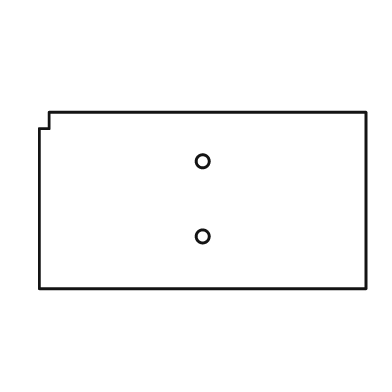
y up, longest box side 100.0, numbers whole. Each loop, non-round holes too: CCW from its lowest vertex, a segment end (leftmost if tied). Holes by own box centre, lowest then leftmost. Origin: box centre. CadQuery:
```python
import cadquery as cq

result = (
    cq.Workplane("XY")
    .moveTo(-50.0, -27.0)
    .lineTo(50.0, -27.0)
    .lineTo(50.0, 27.0)
    .lineTo(-47.0, 27.0)
    .lineTo(-47.0, 22.0)
    .lineTo(-50.0, 22.0)
    .close()
    .moveTo(0.0, -11.0)
    .circle(2.0)
    .moveTo(0.0, 12.0)
    .circle(2.0)
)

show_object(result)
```